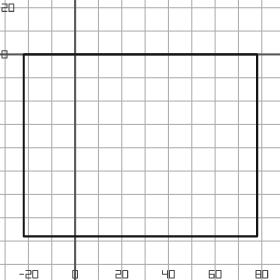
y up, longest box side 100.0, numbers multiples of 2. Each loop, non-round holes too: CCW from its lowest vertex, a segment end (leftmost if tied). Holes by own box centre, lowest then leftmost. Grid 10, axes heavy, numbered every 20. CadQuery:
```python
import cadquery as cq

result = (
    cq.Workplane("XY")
    .moveTo(-22.0, -78.0)
    .lineTo(78.0, -78.0)
    .lineTo(78.0, 0.0)
    .lineTo(-22.0, 0.0)
    .close()
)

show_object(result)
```